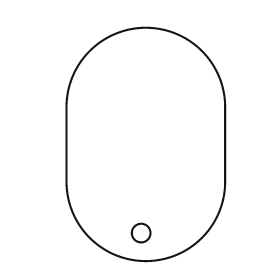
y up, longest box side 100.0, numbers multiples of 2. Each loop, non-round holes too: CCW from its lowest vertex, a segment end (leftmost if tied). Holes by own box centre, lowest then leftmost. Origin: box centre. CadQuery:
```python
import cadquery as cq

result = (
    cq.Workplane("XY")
    .moveTo(-34.0, -16.0)
    .threePointArc((0.0, -50.0), (34.0, -16.0))
    .lineTo(34.0, 16.0)
    .threePointArc((0.0, 50.0), (-34.0, 16.0))
    .close()
    .moveTo(-2.0, -38.0)
    .circle(4.0)
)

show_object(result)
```